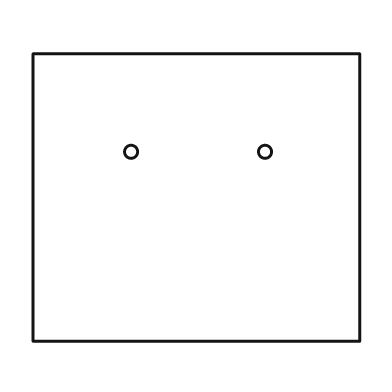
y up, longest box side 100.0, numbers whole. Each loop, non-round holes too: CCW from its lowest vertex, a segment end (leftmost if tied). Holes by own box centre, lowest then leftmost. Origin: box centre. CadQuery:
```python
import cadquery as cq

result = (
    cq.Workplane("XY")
    .moveTo(-50.0, -44.0)
    .lineTo(50.0, -44.0)
    .lineTo(50.0, 44.0)
    .lineTo(-50.0, 44.0)
    .close()
    .moveTo(-20.0, 14.0)
    .circle(2.0)
    .moveTo(21.0, 14.0)
    .circle(2.0)
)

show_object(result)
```